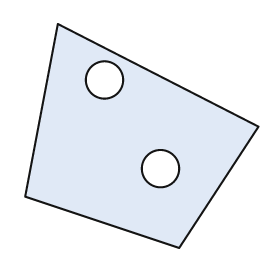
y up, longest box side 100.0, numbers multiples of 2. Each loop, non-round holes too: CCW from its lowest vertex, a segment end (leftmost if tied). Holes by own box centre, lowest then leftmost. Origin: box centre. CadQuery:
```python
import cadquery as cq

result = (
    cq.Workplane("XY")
    .moveTo(16.0, -48.0)
    .lineTo(50.0, 4.0)
    .lineTo(-36.0, 48.0)
    .lineTo(-50.0, -26.0)
    .close()
    .moveTo(8.0, -14.0)
    .circle(8.0)
    .moveTo(-16.0, 24.0)
    .circle(8.0)
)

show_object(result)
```